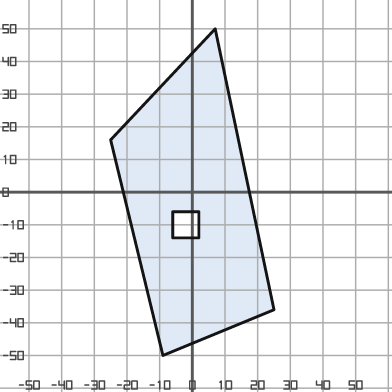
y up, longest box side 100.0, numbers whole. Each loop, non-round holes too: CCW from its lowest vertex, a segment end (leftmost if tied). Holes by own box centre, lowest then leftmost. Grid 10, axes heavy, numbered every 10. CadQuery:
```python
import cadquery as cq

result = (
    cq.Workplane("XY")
    .moveTo(-9.0, -50.0)
    .lineTo(25.0, -36.0)
    .lineTo(7.0, 50.0)
    .lineTo(-25.0, 16.0)
    .close()
    .moveTo(-6.0, -14.0)
    .lineTo(2.0, -14.0)
    .lineTo(2.0, -6.0)
    .lineTo(-6.0, -6.0)
    .close()
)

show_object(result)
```